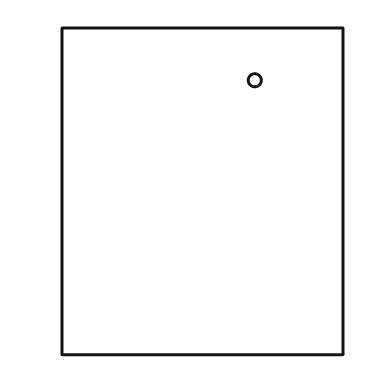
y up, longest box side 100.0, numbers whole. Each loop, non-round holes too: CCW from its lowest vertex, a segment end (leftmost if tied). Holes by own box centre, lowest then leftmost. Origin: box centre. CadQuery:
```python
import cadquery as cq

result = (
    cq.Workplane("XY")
    .moveTo(-43.0, -50.0)
    .lineTo(43.0, -50.0)
    .lineTo(43.0, 50.0)
    .lineTo(-43.0, 50.0)
    .close()
    .moveTo(16.0, 34.0)
    .circle(2.0)
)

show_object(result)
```